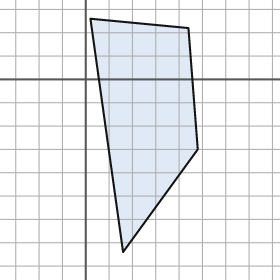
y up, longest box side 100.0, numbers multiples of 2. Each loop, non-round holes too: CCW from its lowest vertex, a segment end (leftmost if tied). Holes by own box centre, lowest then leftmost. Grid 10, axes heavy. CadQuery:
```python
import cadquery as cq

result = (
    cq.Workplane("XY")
    .moveTo(16.0, -74.0)
    .lineTo(48.0, -30.0)
    .lineTo(44.0, 22.0)
    .lineTo(2.0, 26.0)
    .close()
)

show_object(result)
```